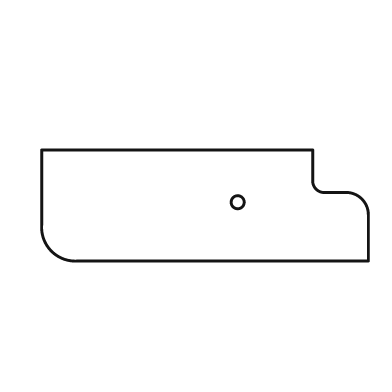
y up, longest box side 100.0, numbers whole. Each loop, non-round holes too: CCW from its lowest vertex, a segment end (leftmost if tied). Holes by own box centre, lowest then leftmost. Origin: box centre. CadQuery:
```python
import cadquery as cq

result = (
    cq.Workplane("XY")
    .moveTo(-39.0, -17.0)
    .lineTo(50.0, -17.0)
    .lineTo(50.0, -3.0)
    .threePointArc((48.0, 2.0), (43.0, 4.0))
    .lineTo(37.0, 4.0)
    .threePointArc((34.0, 5.0), (33.0, 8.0))
    .lineTo(33.0, 17.0)
    .lineTo(-50.0, 17.0)
    .lineTo(-50.0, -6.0)
    .threePointArc((-47.0, -14.0), (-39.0, -17.0))
    .close()
    .moveTo(10.0, 1.0)
    .circle(2.0)
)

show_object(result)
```